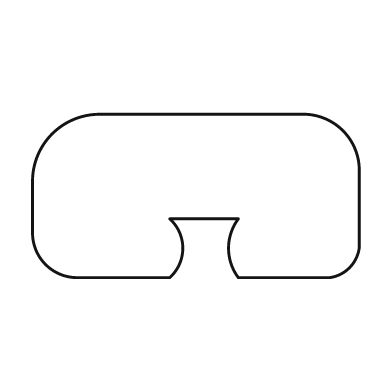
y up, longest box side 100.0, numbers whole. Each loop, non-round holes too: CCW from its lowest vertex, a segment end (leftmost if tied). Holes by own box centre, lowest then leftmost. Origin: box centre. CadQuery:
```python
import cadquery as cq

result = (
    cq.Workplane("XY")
    .moveTo(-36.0, -25.0)
    .lineTo(-8.0, -25.0)
    .threePointArc((-4.0, -16.0), (-8.0, -7.0))
    .lineTo(13.0, -7.0)
    .threePointArc((10.0, -16.0), (13.0, -25.0))
    .lineTo(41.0, -25.0)
    .threePointArc((47.0, -22.0), (50.0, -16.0))
    .lineTo(50.0, 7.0)
    .threePointArc((45.0, 20.0), (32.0, 25.0))
    .lineTo(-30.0, 25.0)
    .threePointArc((-44.0, 19.0), (-50.0, 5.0))
    .lineTo(-50.0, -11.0)
    .threePointArc((-46.0, -21.0), (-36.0, -25.0))
    .close()
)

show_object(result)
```